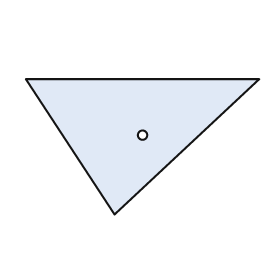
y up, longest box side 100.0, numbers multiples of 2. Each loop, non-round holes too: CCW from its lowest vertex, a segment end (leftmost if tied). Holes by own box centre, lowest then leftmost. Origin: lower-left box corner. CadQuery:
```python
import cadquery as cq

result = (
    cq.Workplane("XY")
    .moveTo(38.0, 0.0)
    .lineTo(100.0, 58.0)
    .lineTo(0.0, 58.0)
    .close()
    .moveTo(50.0, 34.0)
    .circle(2.0)
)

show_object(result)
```